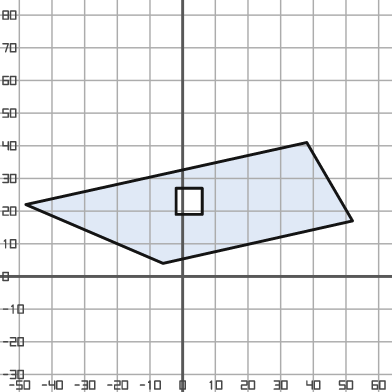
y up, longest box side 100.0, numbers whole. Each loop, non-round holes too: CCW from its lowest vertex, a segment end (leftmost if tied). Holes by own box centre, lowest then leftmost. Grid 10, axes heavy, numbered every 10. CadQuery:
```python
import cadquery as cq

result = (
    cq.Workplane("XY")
    .moveTo(-6.0, 4.0)
    .lineTo(52.0, 17.0)
    .lineTo(38.0, 41.0)
    .lineTo(-48.0, 22.0)
    .close()
    .moveTo(-2.0, 19.0)
    .lineTo(6.0, 19.0)
    .lineTo(6.0, 27.0)
    .lineTo(-2.0, 27.0)
    .close()
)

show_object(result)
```